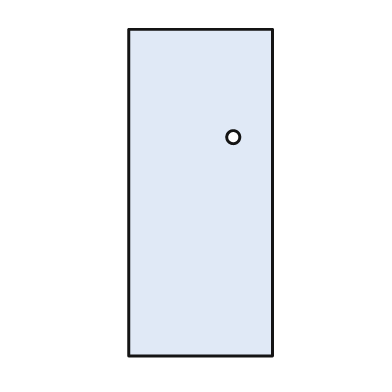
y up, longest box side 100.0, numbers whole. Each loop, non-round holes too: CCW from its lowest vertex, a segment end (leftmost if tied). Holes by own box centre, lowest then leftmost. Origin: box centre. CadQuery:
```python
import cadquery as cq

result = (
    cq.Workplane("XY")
    .moveTo(-22.0, -50.0)
    .lineTo(22.0, -50.0)
    .lineTo(22.0, 50.0)
    .lineTo(-22.0, 50.0)
    .close()
    .moveTo(10.0, 17.0)
    .circle(2.0)
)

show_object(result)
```